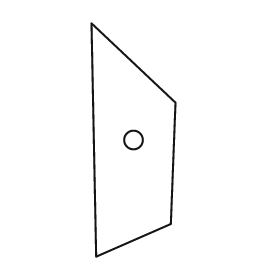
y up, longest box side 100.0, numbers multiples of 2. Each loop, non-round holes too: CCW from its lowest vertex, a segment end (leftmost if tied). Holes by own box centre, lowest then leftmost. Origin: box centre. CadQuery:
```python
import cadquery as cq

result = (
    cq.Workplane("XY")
    .moveTo(-16.0, -50.0)
    .lineTo(16.0, -36.0)
    .lineTo(18.0, 16.0)
    .lineTo(-18.0, 50.0)
    .close()
    .moveTo(0.0, 0.0)
    .circle(4.0)
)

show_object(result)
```